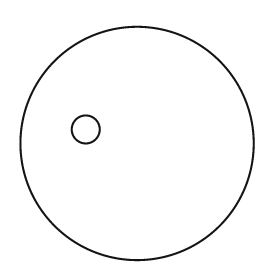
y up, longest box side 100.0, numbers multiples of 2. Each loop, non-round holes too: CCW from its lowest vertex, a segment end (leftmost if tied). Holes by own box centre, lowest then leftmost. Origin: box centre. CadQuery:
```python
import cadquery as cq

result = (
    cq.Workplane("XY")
    .moveTo(0.0, 0.0)
    .circle(50.0)
    .moveTo(-22.0, 6.0)
    .circle(6.0)
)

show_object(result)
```